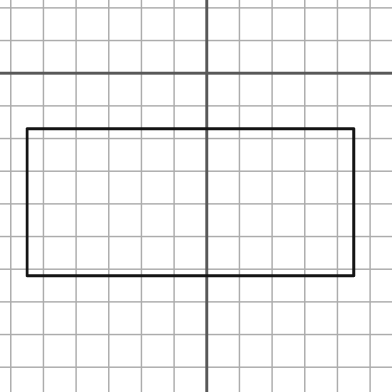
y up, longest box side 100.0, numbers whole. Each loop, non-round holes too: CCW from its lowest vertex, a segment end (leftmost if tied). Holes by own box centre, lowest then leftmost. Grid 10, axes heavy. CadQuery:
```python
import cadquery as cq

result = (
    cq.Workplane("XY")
    .moveTo(-55.0, -62.0)
    .lineTo(45.0, -62.0)
    .lineTo(45.0, -17.0)
    .lineTo(-55.0, -17.0)
    .close()
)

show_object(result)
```